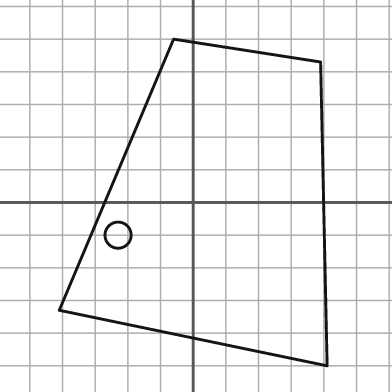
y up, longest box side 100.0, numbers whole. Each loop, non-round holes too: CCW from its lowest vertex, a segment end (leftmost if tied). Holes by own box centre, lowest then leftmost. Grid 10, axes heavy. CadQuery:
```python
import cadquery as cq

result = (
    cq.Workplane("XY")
    .moveTo(41.0, -50.0)
    .lineTo(39.0, 43.0)
    .lineTo(-6.0, 50.0)
    .lineTo(-41.0, -33.0)
    .close()
    .moveTo(-23.0, -10.0)
    .circle(4.0)
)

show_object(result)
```